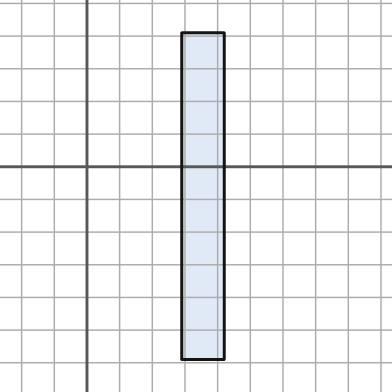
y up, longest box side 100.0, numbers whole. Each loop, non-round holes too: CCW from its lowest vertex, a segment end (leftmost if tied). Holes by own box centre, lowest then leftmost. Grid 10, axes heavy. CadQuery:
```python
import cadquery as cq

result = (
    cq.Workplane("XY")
    .moveTo(29.0, -59.0)
    .lineTo(42.0, -59.0)
    .lineTo(42.0, 41.0)
    .lineTo(29.0, 41.0)
    .close()
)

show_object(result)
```